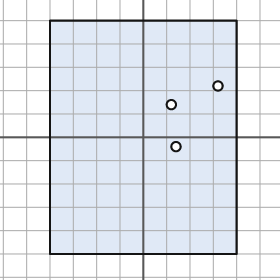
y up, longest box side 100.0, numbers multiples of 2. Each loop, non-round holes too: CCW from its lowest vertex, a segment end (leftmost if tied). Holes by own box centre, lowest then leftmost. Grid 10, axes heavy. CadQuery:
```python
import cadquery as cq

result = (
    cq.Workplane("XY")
    .moveTo(-40.0, -50.0)
    .lineTo(40.0, -50.0)
    .lineTo(40.0, 50.0)
    .lineTo(-40.0, 50.0)
    .close()
    .moveTo(14.0, -4.0)
    .circle(2.0)
    .moveTo(12.0, 14.0)
    .circle(2.0)
    .moveTo(32.0, 22.0)
    .circle(2.0)
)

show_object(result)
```